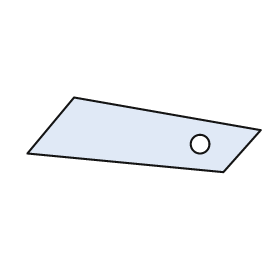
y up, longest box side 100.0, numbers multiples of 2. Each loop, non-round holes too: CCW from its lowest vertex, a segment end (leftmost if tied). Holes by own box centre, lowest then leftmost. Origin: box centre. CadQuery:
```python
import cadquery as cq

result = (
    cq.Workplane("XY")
    .moveTo(34.0, -16.0)
    .lineTo(50.0, 2.0)
    .lineTo(-30.0, 16.0)
    .lineTo(-50.0, -8.0)
    .close()
    .moveTo(24.0, -4.0)
    .circle(4.0)
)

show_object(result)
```